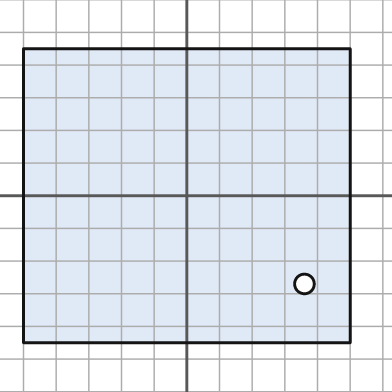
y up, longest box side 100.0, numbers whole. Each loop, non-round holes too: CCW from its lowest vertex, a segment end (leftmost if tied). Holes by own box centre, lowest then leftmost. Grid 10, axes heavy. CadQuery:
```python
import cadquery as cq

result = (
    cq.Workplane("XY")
    .moveTo(-50.0, -45.0)
    .lineTo(50.0, -45.0)
    .lineTo(50.0, 45.0)
    .lineTo(-50.0, 45.0)
    .close()
    .moveTo(36.0, -27.0)
    .circle(3.0)
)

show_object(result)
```